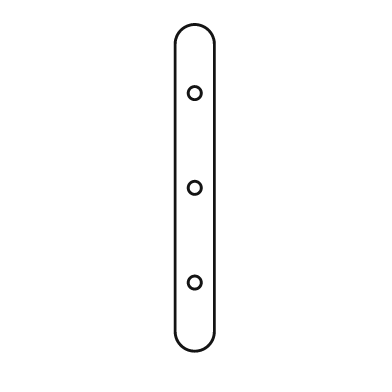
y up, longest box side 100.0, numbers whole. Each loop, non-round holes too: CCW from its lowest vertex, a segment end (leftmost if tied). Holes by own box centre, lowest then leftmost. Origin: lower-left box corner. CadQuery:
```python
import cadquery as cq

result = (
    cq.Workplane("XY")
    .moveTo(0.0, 6.0)
    .threePointArc((6.0, 0.0), (12.0, 6.0))
    .lineTo(12.0, 94.0)
    .threePointArc((6.0, 100.0), (0.0, 94.0))
    .close()
    .moveTo(6.0, 21.0)
    .circle(2.0)
    .moveTo(6.0, 50.0)
    .circle(2.0)
    .moveTo(6.0, 79.0)
    .circle(2.0)
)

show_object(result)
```